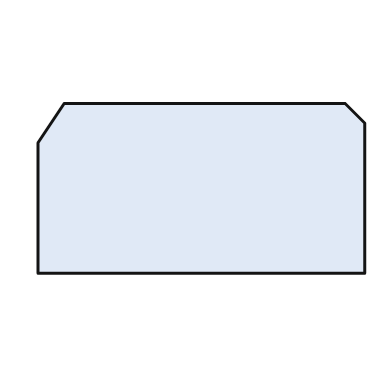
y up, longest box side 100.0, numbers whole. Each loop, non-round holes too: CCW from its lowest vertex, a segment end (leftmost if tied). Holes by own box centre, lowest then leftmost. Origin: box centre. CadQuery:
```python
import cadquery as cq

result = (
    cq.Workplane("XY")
    .moveTo(-50.0, -26.0)
    .lineTo(50.0, -26.0)
    .lineTo(50.0, 20.0)
    .lineTo(44.0, 26.0)
    .lineTo(-42.0, 26.0)
    .lineTo(-50.0, 14.0)
    .close()
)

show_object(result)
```